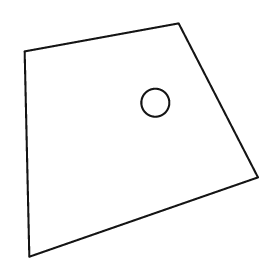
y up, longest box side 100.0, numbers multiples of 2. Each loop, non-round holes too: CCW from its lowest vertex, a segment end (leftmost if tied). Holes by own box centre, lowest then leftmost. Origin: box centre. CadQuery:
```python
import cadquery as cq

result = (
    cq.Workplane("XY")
    .moveTo(-48.0, -50.0)
    .lineTo(50.0, -16.0)
    .lineTo(16.0, 50.0)
    .lineTo(-50.0, 38.0)
    .close()
    .moveTo(6.0, 16.0)
    .circle(6.0)
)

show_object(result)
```